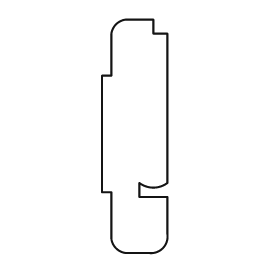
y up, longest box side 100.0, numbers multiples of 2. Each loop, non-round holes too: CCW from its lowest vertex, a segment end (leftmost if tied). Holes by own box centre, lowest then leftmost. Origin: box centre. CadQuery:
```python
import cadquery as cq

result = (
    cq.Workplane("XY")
    .moveTo(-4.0, -50.0)
    .lineTo(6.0, -50.0)
    .threePointArc((12.0, -48.0), (14.0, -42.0))
    .lineTo(14.0, -26.0)
    .lineTo(2.0, -26.0)
    .lineTo(2.0, -20.0)
    .threePointArc((8.0, -22.0), (14.0, -20.0))
    .lineTo(14.0, 44.0)
    .lineTo(8.0, 44.0)
    .lineTo(8.0, 50.0)
    .lineTo(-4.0, 50.0)
    .threePointArc((-8.0, 48.0), (-10.0, 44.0))
    .lineTo(-10.0, 26.0)
    .lineTo(-14.0, 26.0)
    .lineTo(-14.0, -24.0)
    .lineTo(-10.0, -24.0)
    .lineTo(-10.0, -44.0)
    .threePointArc((-8.0, -48.0), (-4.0, -50.0))
    .close()
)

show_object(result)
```